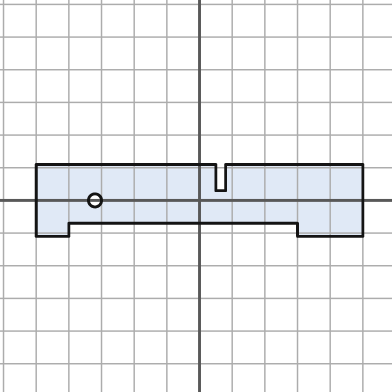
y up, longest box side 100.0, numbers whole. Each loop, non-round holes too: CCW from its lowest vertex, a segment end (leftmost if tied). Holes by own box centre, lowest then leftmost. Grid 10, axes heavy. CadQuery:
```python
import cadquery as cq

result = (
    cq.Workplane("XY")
    .moveTo(-50.0, -11.0)
    .lineTo(-40.0, -11.0)
    .lineTo(-40.0, -7.0)
    .lineTo(30.0, -7.0)
    .lineTo(30.0, -11.0)
    .lineTo(50.0, -11.0)
    .lineTo(50.0, 11.0)
    .lineTo(8.0, 11.0)
    .lineTo(8.0, 3.0)
    .lineTo(5.0, 3.0)
    .lineTo(5.0, 11.0)
    .lineTo(-50.0, 11.0)
    .close()
    .moveTo(-32.0, 0.0)
    .circle(2.0)
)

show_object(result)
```